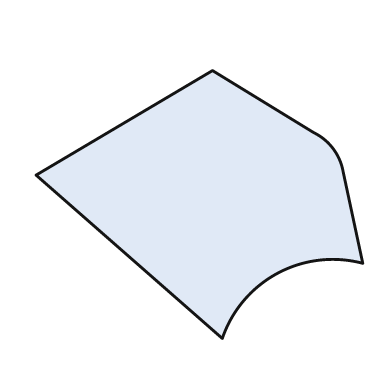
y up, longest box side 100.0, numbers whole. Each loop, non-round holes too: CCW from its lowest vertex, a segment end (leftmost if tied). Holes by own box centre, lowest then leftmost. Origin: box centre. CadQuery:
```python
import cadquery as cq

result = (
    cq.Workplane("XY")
    .moveTo(7.0, -41.0)
    .threePointArc((24.0, -21.0), (50.0, -18.0))
    .lineTo(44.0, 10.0)
    .threePointArc((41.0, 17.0), (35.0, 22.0))
    .lineTo(4.0, 41.0)
    .lineTo(-50.0, 9.0)
    .close()
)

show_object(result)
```